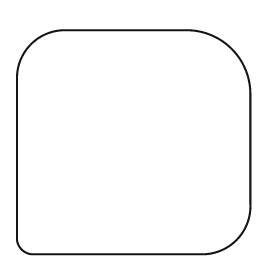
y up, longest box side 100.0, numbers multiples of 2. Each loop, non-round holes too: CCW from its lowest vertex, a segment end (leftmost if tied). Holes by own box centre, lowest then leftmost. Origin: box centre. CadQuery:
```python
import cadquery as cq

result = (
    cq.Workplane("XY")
    .moveTo(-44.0, -48.0)
    .lineTo(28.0, -48.0)
    .threePointArc((44.0, -42.0), (50.0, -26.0))
    .lineTo(50.0, 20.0)
    .threePointArc((42.0, 40.0), (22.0, 48.0))
    .lineTo(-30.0, 48.0)
    .threePointArc((-44.0, 42.0), (-50.0, 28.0))
    .lineTo(-50.0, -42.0)
    .threePointArc((-48.0, -46.0), (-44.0, -48.0))
    .close()
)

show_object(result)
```